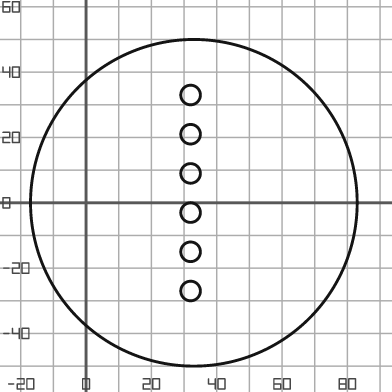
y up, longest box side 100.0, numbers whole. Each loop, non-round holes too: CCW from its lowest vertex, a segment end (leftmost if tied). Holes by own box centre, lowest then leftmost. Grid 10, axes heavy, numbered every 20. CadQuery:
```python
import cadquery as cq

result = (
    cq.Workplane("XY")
    .moveTo(33.0, 0.0)
    .circle(50.0)
    .moveTo(32.0, -27.0)
    .circle(3.0)
    .moveTo(32.0, -15.0)
    .circle(3.0)
    .moveTo(32.0, -3.0)
    .circle(3.0)
    .moveTo(32.0, 9.0)
    .circle(3.0)
    .moveTo(32.0, 21.0)
    .circle(3.0)
    .moveTo(32.0, 33.0)
    .circle(3.0)
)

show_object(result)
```